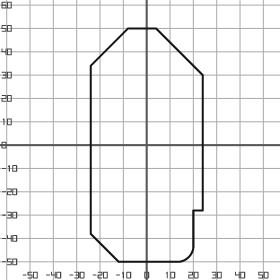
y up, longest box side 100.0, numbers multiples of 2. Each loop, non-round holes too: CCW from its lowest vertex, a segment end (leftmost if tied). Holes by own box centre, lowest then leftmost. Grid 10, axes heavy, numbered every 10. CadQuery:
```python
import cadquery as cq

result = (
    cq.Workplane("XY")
    .moveTo(-12.0, -50.0)
    .lineTo(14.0, -50.0)
    .threePointArc((18.0, -48.0), (20.0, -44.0))
    .lineTo(20.0, -28.0)
    .lineTo(24.0, -28.0)
    .lineTo(24.0, 30.0)
    .lineTo(4.0, 50.0)
    .lineTo(-8.0, 50.0)
    .lineTo(-24.0, 34.0)
    .lineTo(-24.0, -38.0)
    .close()
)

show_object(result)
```